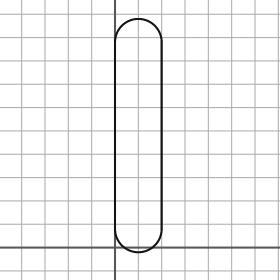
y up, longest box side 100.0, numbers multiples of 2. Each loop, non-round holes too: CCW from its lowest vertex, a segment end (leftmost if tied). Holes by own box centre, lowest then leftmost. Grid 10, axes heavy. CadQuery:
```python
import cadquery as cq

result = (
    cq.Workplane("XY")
    .moveTo(0.0, 8.0)
    .threePointArc((10.0, -2.0), (20.0, 8.0))
    .lineTo(20.0, 88.0)
    .threePointArc((10.0, 98.0), (0.0, 88.0))
    .close()
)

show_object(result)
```